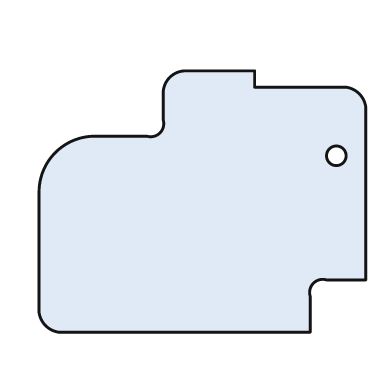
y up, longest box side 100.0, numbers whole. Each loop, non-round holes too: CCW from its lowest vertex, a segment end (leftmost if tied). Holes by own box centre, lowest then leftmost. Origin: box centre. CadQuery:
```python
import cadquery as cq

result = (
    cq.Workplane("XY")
    .moveTo(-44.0, -40.0)
    .lineTo(33.0, -40.0)
    .lineTo(33.0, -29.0)
    .threePointArc((34.0, -25.0), (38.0, -24.0))
    .lineTo(50.0, -24.0)
    .lineTo(50.0, 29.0)
    .threePointArc((48.0, 33.0), (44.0, 35.0))
    .lineTo(16.0, 35.0)
    .lineTo(16.0, 40.0)
    .lineTo(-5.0, 40.0)
    .threePointArc((-10.0, 38.0), (-12.0, 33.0))
    .lineTo(-12.0, 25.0)
    .threePointArc((-13.0, 21.0), (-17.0, 20.0))
    .lineTo(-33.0, 20.0)
    .threePointArc((-45.0, 15.0), (-50.0, 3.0))
    .lineTo(-50.0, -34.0)
    .threePointArc((-48.0, -38.0), (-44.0, -40.0))
    .close()
    .moveTo(41.0, 14.0)
    .circle(3.0)
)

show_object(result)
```